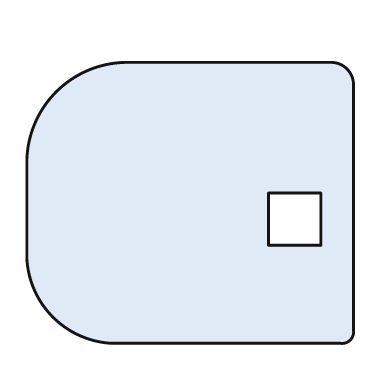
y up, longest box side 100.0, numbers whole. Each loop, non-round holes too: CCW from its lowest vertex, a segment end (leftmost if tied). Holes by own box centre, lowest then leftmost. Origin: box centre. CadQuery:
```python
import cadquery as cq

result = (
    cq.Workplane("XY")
    .moveTo(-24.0, -43.0)
    .lineTo(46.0, -43.0)
    .threePointArc((49.0, -42.0), (50.0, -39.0))
    .lineTo(50.0, 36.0)
    .threePointArc((48.0, 41.0), (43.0, 43.0))
    .lineTo(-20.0, 43.0)
    .threePointArc((-41.0, 34.0), (-50.0, 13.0))
    .lineTo(-50.0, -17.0)
    .threePointArc((-42.0, -35.0), (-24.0, -43.0))
    .close()
    .moveTo(24.0, -13.0)
    .lineTo(40.0, -13.0)
    .lineTo(40.0, 3.0)
    .lineTo(24.0, 3.0)
    .close()
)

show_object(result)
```